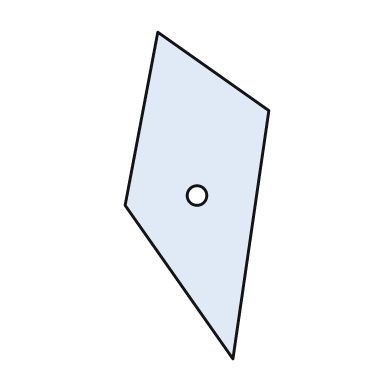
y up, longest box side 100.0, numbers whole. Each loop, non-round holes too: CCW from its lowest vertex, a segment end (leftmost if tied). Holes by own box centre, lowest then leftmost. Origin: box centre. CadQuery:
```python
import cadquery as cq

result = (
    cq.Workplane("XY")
    .moveTo(11.0, -50.0)
    .lineTo(22.0, 26.0)
    .lineTo(-12.0, 50.0)
    .lineTo(-22.0, -3.0)
    .close()
    .moveTo(0.0, 0.0)
    .circle(3.0)
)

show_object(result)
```